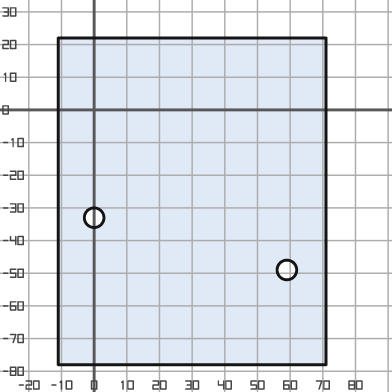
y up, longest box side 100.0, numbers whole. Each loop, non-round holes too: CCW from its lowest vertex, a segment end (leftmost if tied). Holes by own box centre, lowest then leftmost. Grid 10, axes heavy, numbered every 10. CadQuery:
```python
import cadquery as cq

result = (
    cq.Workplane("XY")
    .moveTo(-11.0, -78.0)
    .lineTo(71.0, -78.0)
    .lineTo(71.0, 22.0)
    .lineTo(-11.0, 22.0)
    .close()
    .moveTo(59.0, -49.0)
    .circle(3.0)
    .moveTo(0.0, -33.0)
    .circle(3.0)
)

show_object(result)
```